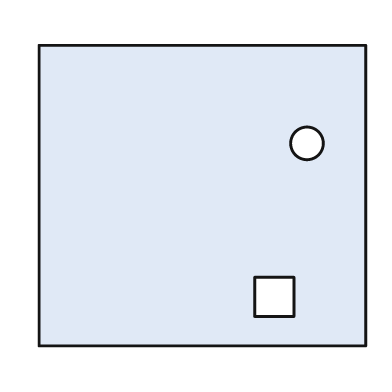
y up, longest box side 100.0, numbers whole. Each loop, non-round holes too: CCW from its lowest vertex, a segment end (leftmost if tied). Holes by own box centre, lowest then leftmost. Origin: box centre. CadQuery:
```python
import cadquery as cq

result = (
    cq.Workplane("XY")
    .moveTo(-50.0, -46.0)
    .lineTo(50.0, -46.0)
    .lineTo(50.0, 46.0)
    .lineTo(-50.0, 46.0)
    .close()
    .moveTo(16.0, -37.0)
    .lineTo(28.0, -37.0)
    .lineTo(28.0, -25.0)
    .lineTo(16.0, -25.0)
    .close()
    .moveTo(32.0, 16.0)
    .circle(5.0)
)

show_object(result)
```